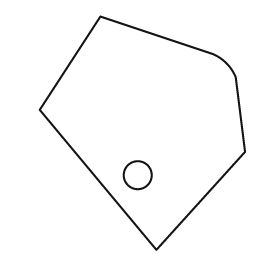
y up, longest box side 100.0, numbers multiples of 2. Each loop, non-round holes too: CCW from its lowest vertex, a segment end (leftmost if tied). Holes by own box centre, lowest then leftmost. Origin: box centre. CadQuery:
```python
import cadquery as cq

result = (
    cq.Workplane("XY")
    .moveTo(6.0, -50.0)
    .lineTo(44.0, -8.0)
    .lineTo(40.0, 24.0)
    .threePointArc((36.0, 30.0), (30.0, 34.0))
    .lineTo(-18.0, 50.0)
    .lineTo(-44.0, 10.0)
    .close()
    .moveTo(-2.0, -18.0)
    .circle(6.0)
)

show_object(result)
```